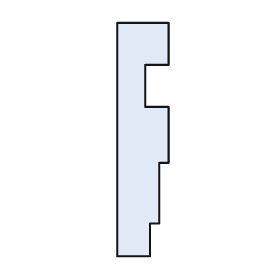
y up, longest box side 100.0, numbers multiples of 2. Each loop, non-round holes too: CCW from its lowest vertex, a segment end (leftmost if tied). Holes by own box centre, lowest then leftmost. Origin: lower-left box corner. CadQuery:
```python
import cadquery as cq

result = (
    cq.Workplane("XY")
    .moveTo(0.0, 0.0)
    .lineTo(14.0, 0.0)
    .lineTo(14.0, 14.0)
    .lineTo(18.0, 14.0)
    .lineTo(18.0, 40.0)
    .lineTo(22.0, 40.0)
    .lineTo(22.0, 64.0)
    .lineTo(12.0, 64.0)
    .lineTo(12.0, 82.0)
    .lineTo(22.0, 82.0)
    .lineTo(22.0, 100.0)
    .lineTo(0.0, 100.0)
    .close()
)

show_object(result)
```